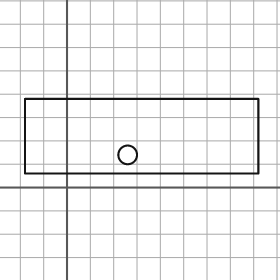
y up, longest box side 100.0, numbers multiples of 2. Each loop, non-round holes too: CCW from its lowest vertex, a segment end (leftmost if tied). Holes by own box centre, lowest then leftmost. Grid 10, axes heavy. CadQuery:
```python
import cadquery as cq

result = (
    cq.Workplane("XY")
    .moveTo(-18.0, 6.0)
    .lineTo(82.0, 6.0)
    .lineTo(82.0, 38.0)
    .lineTo(-18.0, 38.0)
    .close()
    .moveTo(26.0, 14.0)
    .circle(4.0)
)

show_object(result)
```